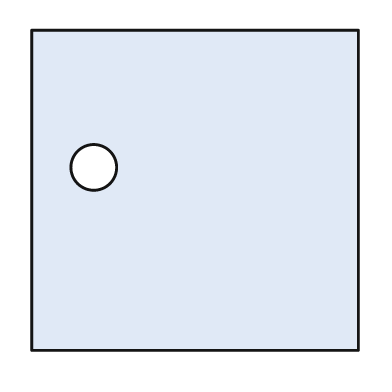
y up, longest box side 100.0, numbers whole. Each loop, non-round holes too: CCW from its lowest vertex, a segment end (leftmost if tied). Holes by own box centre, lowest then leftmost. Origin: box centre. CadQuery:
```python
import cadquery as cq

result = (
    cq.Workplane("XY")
    .moveTo(-50.0, -49.0)
    .lineTo(50.0, -49.0)
    .lineTo(50.0, 49.0)
    .lineTo(-50.0, 49.0)
    .close()
    .moveTo(-31.0, 7.0)
    .circle(7.0)
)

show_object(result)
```